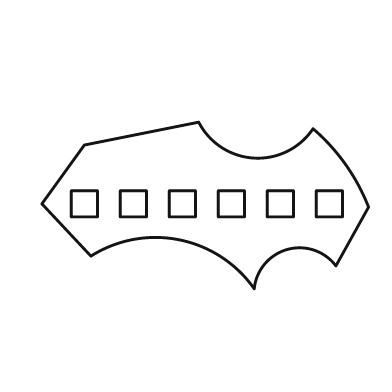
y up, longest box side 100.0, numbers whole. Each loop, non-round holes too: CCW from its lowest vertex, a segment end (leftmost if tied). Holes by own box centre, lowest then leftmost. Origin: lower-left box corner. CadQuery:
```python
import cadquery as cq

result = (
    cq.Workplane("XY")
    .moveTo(65.0, 0.0)
    .threePointArc((75.0, 12.0), (90.0, 7.0))
    .lineTo(100.0, 25.0)
    .threePointArc((93.0, 38.0), (83.0, 49.0))
    .threePointArc((65.0, 40.0), (48.0, 51.0))
    .lineTo(13.0, 44.0)
    .lineTo(0.0, 26.0)
    .lineTo(15.0, 10.0)
    .threePointArc((42.0, 15.0), (65.0, 0.0))
    .close()
    .moveTo(9.0, 22.0)
    .lineTo(17.0, 22.0)
    .lineTo(17.0, 30.0)
    .lineTo(9.0, 30.0)
    .close()
    .moveTo(24.0, 22.0)
    .lineTo(32.0, 22.0)
    .lineTo(32.0, 30.0)
    .lineTo(24.0, 30.0)
    .close()
    .moveTo(39.0, 22.0)
    .lineTo(47.0, 22.0)
    .lineTo(47.0, 30.0)
    .lineTo(39.0, 30.0)
    .close()
    .moveTo(54.0, 22.0)
    .lineTo(62.0, 22.0)
    .lineTo(62.0, 30.0)
    .lineTo(54.0, 30.0)
    .close()
    .moveTo(69.0, 22.0)
    .lineTo(77.0, 22.0)
    .lineTo(77.0, 30.0)
    .lineTo(69.0, 30.0)
    .close()
    .moveTo(84.0, 22.0)
    .lineTo(92.0, 22.0)
    .lineTo(92.0, 30.0)
    .lineTo(84.0, 30.0)
    .close()
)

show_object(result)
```